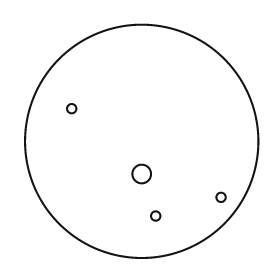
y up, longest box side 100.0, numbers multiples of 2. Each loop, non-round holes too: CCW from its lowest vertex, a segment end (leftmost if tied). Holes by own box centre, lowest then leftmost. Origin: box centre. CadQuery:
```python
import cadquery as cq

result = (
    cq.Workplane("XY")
    .moveTo(0.0, 0.0)
    .circle(50.0)
    .moveTo(6.0, -32.0)
    .circle(2.0)
    .moveTo(34.0, -24.0)
    .circle(2.0)
    .moveTo(0.0, -14.0)
    .circle(4.0)
    .moveTo(-30.0, 14.0)
    .circle(2.0)
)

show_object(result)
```